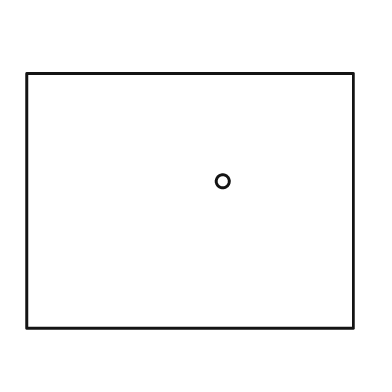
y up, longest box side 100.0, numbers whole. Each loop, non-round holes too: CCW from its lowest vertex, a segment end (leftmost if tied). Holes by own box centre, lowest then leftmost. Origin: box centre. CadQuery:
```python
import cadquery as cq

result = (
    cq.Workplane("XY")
    .moveTo(-50.0, -39.0)
    .lineTo(50.0, -39.0)
    .lineTo(50.0, 39.0)
    .lineTo(-50.0, 39.0)
    .close()
    .moveTo(10.0, 6.0)
    .circle(2.0)
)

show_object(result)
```